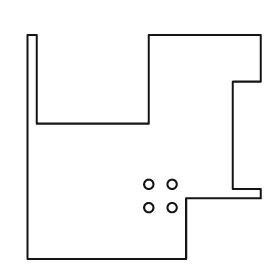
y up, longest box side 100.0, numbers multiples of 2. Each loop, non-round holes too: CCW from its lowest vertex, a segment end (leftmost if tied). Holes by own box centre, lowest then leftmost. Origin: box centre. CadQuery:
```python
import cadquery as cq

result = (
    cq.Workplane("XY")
    .moveTo(-50.0, -48.0)
    .lineTo(18.0, -48.0)
    .lineTo(18.0, -22.0)
    .lineTo(50.0, -22.0)
    .lineTo(50.0, -18.0)
    .lineTo(38.0, -18.0)
    .lineTo(38.0, 28.0)
    .lineTo(50.0, 28.0)
    .lineTo(50.0, 48.0)
    .lineTo(2.0, 48.0)
    .lineTo(2.0, 10.0)
    .lineTo(-46.0, 10.0)
    .lineTo(-46.0, 48.0)
    .lineTo(-50.0, 48.0)
    .close()
    .moveTo(2.0, -26.0)
    .circle(2.0)
    .moveTo(12.0, -26.0)
    .circle(2.0)
    .moveTo(2.0, -16.0)
    .circle(2.0)
    .moveTo(12.0, -16.0)
    .circle(2.0)
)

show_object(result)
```